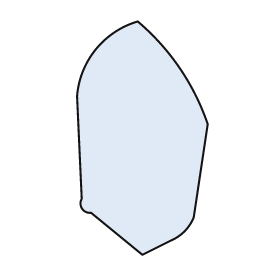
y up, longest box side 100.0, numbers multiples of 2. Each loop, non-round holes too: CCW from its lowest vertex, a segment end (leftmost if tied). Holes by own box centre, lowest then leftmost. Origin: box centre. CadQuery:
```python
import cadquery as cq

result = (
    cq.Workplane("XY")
    .moveTo(0.0, -50.0)
    .lineTo(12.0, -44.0)
    .threePointArc((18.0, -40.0), (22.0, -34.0))
    .lineTo(28.0, 6.0)
    .threePointArc((16.0, 30.0), (-2.0, 50.0))
    .threePointArc((-20.0, 38.0), (-28.0, 18.0))
    .lineTo(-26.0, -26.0)
    .threePointArc((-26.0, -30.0), (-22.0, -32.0))
    .close()
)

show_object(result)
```